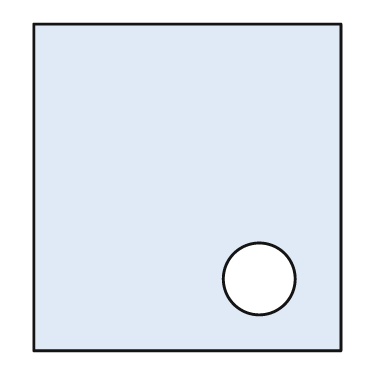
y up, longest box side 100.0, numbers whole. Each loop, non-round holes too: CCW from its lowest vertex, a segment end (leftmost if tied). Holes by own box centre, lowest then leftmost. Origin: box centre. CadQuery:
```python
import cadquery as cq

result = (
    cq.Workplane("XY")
    .moveTo(-47.0, -50.0)
    .lineTo(47.0, -50.0)
    .lineTo(47.0, 50.0)
    .lineTo(-47.0, 50.0)
    .close()
    .moveTo(22.0, -28.0)
    .circle(11.0)
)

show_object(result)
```